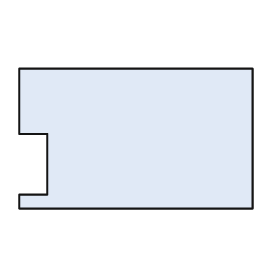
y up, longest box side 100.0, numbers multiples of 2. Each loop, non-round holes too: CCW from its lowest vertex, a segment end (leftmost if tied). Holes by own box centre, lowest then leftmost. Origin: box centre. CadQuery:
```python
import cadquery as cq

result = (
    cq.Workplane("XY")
    .moveTo(-50.0, -30.0)
    .lineTo(50.0, -30.0)
    .lineTo(50.0, 30.0)
    .lineTo(-50.0, 30.0)
    .lineTo(-50.0, 2.0)
    .lineTo(-38.0, 2.0)
    .lineTo(-38.0, -24.0)
    .lineTo(-50.0, -24.0)
    .close()
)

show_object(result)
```